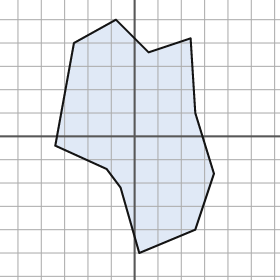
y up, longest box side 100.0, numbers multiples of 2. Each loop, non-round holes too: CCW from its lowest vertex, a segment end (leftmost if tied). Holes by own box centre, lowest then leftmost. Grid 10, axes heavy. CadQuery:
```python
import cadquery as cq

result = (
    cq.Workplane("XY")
    .moveTo(2.0, -50.0)
    .lineTo(26.0, -40.0)
    .lineTo(34.0, -16.0)
    .lineTo(26.0, 10.0)
    .lineTo(24.0, 42.0)
    .lineTo(6.0, 36.0)
    .lineTo(-8.0, 50.0)
    .lineTo(-26.0, 40.0)
    .lineTo(-34.0, -4.0)
    .lineTo(-12.0, -14.0)
    .lineTo(-6.0, -22.0)
    .close()
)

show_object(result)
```